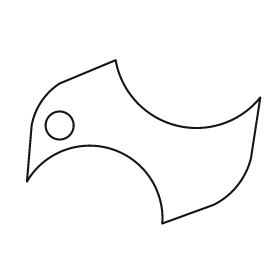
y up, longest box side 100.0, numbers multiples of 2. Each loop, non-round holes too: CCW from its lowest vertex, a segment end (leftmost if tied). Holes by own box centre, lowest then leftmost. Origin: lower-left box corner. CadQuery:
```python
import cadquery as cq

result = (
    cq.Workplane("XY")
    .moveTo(58.0, 0.0)
    .lineTo(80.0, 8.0)
    .threePointArc((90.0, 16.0), (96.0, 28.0))
    .lineTo(100.0, 54.0)
    .threePointArc((64.0, 42.0), (38.0, 70.0))
    .lineTo(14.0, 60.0)
    .threePointArc((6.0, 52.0), (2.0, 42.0))
    .lineTo(0.0, 18.0)
    .threePointArc((36.0, 32.0), (58.0, 0.0))
    .close()
    .moveTo(14.0, 42.0)
    .circle(6.0)
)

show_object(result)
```